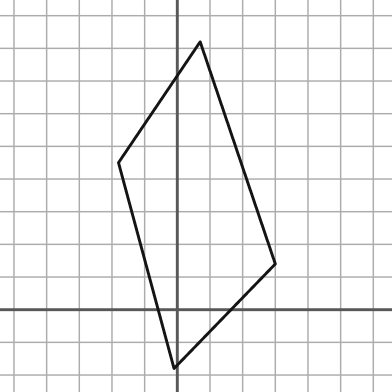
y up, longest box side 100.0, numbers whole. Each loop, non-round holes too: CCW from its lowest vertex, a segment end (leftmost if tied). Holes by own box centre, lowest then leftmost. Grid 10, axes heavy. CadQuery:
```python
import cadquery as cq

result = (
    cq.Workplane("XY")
    .moveTo(-1.0, -18.0)
    .lineTo(30.0, 14.0)
    .lineTo(7.0, 82.0)
    .lineTo(-18.0, 45.0)
    .close()
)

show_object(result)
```